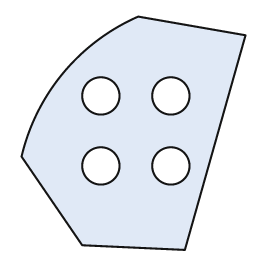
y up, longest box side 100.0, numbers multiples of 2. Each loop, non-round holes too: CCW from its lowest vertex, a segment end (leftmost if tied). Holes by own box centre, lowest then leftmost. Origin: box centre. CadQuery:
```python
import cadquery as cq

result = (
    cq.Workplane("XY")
    .moveTo(22.0, -50.0)
    .lineTo(48.0, 42.0)
    .lineTo(2.0, 50.0)
    .threePointArc((-30.0, 26.0), (-48.0, -10.0))
    .lineTo(-22.0, -48.0)
    .close()
    .moveTo(-14.0, -14.0)
    .circle(8.0)
    .moveTo(16.0, -14.0)
    .circle(8.0)
    .moveTo(-14.0, 16.0)
    .circle(8.0)
    .moveTo(16.0, 16.0)
    .circle(8.0)
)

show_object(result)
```